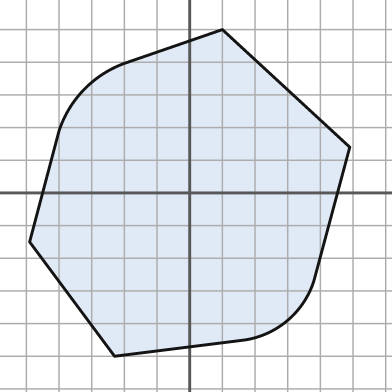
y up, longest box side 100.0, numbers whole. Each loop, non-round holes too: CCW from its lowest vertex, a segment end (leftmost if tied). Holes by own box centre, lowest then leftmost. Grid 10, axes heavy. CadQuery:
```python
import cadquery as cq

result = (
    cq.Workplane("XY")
    .moveTo(-23.0, -50.0)
    .lineTo(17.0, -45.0)
    .threePointArc((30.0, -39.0), (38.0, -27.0))
    .lineTo(49.0, 14.0)
    .lineTo(10.0, 50.0)
    .lineTo(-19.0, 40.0)
    .threePointArc((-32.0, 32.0), (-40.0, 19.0))
    .lineTo(-49.0, -15.0)
    .close()
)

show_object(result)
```